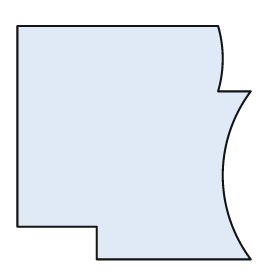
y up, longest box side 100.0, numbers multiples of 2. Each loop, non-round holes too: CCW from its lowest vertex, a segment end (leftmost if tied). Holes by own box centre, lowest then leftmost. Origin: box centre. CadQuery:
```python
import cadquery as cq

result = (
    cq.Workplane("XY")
    .moveTo(-16.0, -50.0)
    .lineTo(50.0, -50.0)
    .threePointArc((38.0, -14.0), (50.0, 22.0))
    .lineTo(36.0, 22.0)
    .threePointArc((38.0, 36.0), (36.0, 50.0))
    .lineTo(-50.0, 50.0)
    .lineTo(-50.0, -36.0)
    .lineTo(-16.0, -36.0)
    .close()
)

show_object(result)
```